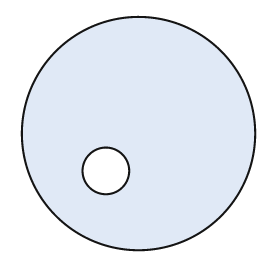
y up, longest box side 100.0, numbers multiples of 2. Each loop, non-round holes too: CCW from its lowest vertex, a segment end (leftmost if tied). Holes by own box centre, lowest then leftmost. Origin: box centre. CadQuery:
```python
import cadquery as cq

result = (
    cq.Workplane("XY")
    .moveTo(0.0, 0.0)
    .circle(50.0)
    .moveTo(-14.0, -16.0)
    .circle(10.0)
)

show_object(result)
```